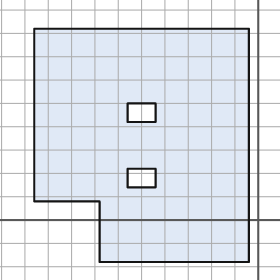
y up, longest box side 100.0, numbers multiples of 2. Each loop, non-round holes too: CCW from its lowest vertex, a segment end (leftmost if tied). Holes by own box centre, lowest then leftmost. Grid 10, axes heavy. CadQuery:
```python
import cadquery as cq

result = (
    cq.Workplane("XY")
    .moveTo(-68.0, -18.0)
    .lineTo(-4.0, -18.0)
    .lineTo(-4.0, 82.0)
    .lineTo(-96.0, 82.0)
    .lineTo(-96.0, 8.0)
    .lineTo(-68.0, 8.0)
    .close()
    .moveTo(-56.0, 14.0)
    .lineTo(-44.0, 14.0)
    .lineTo(-44.0, 22.0)
    .lineTo(-56.0, 22.0)
    .close()
    .moveTo(-56.0, 42.0)
    .lineTo(-44.0, 42.0)
    .lineTo(-44.0, 50.0)
    .lineTo(-56.0, 50.0)
    .close()
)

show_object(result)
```